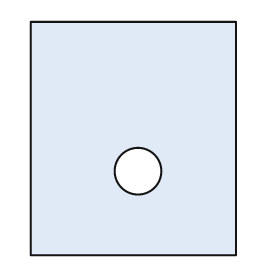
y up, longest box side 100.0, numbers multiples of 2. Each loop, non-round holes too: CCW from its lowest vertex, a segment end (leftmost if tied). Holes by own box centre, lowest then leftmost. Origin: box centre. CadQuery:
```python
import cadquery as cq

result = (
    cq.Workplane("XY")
    .moveTo(-44.0, -50.0)
    .lineTo(44.0, -50.0)
    .lineTo(44.0, 50.0)
    .lineTo(-44.0, 50.0)
    .close()
    .moveTo(2.0, -14.0)
    .circle(10.0)
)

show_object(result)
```